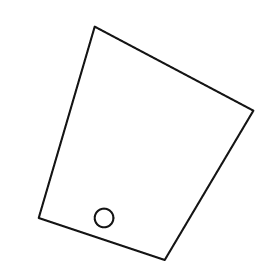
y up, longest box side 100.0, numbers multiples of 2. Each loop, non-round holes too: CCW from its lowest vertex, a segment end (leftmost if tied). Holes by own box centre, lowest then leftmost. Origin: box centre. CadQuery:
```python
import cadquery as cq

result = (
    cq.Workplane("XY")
    .moveTo(8.0, -50.0)
    .lineTo(46.0, 14.0)
    .lineTo(-22.0, 50.0)
    .lineTo(-46.0, -32.0)
    .close()
    .moveTo(-18.0, -32.0)
    .circle(4.0)
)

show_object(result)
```